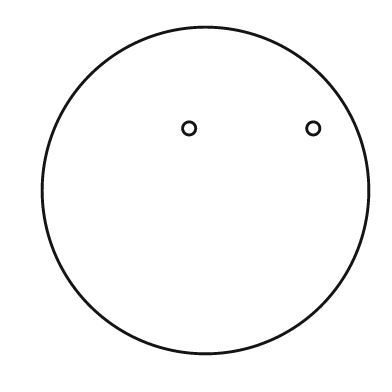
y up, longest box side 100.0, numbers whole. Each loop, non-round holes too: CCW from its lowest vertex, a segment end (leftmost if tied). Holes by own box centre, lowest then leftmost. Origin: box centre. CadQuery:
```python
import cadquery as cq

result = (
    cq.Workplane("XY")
    .moveTo(0.0, 0.0)
    .circle(50.0)
    .moveTo(-5.0, 19.0)
    .circle(2.0)
    .moveTo(33.0, 19.0)
    .circle(2.0)
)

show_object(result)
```